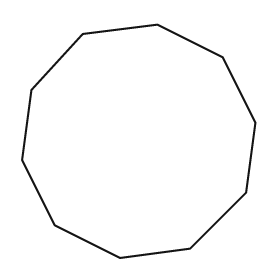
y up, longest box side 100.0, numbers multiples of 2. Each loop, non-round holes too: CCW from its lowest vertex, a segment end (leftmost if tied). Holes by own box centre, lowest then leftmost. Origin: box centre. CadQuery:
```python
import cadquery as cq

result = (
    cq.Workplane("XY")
    .moveTo(-8.0, -50.0)
    .lineTo(22.0, -46.0)
    .lineTo(46.0, -22.0)
    .lineTo(50.0, 8.0)
    .lineTo(36.0, 36.0)
    .lineTo(8.0, 50.0)
    .lineTo(-24.0, 46.0)
    .lineTo(-46.0, 22.0)
    .lineTo(-50.0, -8.0)
    .lineTo(-36.0, -36.0)
    .close()
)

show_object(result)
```